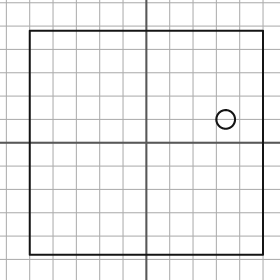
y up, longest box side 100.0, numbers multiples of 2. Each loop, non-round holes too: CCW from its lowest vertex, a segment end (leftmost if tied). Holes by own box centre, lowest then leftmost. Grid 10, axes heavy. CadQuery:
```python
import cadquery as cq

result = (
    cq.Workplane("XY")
    .moveTo(-50.0, -48.0)
    .lineTo(50.0, -48.0)
    .lineTo(50.0, 48.0)
    .lineTo(-50.0, 48.0)
    .close()
    .moveTo(34.0, 10.0)
    .circle(4.0)
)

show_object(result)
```